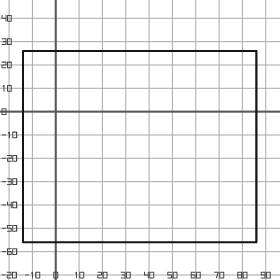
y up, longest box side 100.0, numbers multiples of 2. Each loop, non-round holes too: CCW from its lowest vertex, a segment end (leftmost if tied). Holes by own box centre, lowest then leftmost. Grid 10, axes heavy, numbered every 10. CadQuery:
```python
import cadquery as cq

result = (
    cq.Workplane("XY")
    .moveTo(-14.0, -56.0)
    .lineTo(86.0, -56.0)
    .lineTo(86.0, 26.0)
    .lineTo(-14.0, 26.0)
    .close()
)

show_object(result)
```